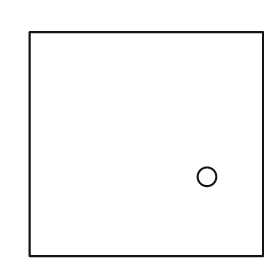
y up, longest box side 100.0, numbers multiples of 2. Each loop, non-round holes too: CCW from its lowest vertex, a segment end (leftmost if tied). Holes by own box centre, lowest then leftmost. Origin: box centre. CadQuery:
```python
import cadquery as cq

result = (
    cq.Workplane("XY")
    .moveTo(-50.0, -48.0)
    .lineTo(50.0, -48.0)
    .lineTo(50.0, 48.0)
    .lineTo(-50.0, 48.0)
    .close()
    .moveTo(26.0, -14.0)
    .circle(4.0)
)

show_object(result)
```